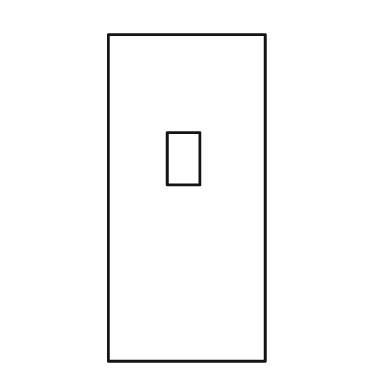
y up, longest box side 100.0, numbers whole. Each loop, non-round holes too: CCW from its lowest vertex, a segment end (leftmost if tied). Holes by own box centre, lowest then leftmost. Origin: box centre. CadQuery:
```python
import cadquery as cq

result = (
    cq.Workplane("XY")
    .moveTo(-24.0, -50.0)
    .lineTo(24.0, -50.0)
    .lineTo(24.0, 50.0)
    .lineTo(-24.0, 50.0)
    .close()
    .moveTo(-6.0, 4.0)
    .lineTo(4.0, 4.0)
    .lineTo(4.0, 20.0)
    .lineTo(-6.0, 20.0)
    .close()
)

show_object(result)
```